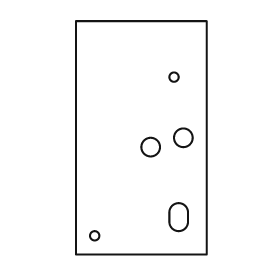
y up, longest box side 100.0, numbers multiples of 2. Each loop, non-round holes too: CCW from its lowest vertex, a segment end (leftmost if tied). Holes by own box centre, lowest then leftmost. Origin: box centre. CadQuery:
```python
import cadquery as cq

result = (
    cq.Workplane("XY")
    .moveTo(-28.0, -50.0)
    .lineTo(28.0, -50.0)
    .lineTo(28.0, 50.0)
    .lineTo(-28.0, 50.0)
    .close()
    .moveTo(-20.0, -42.0)
    .circle(2.0)
    .moveTo(12.0, -36.0)
    .threePointArc((16.0, -40.0), (20.0, -36.0))
    .lineTo(20.0, -32.0)
    .threePointArc((16.0, -28.0), (12.0, -32.0))
    .close()
    .moveTo(4.0, -4.0)
    .circle(4.0)
    .moveTo(18.0, 0.0)
    .circle(4.0)
    .moveTo(14.0, 26.0)
    .circle(2.0)
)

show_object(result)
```